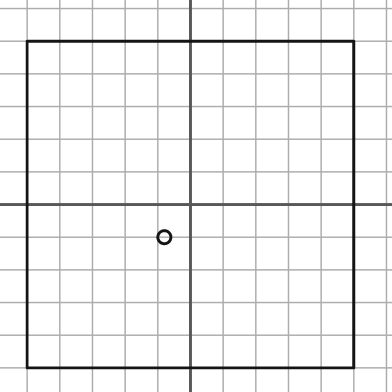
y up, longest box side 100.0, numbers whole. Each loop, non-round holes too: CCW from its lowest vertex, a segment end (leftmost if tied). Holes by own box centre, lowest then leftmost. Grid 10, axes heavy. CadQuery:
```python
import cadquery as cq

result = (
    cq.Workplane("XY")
    .moveTo(-50.0, -50.0)
    .lineTo(50.0, -50.0)
    .lineTo(50.0, 50.0)
    .lineTo(-50.0, 50.0)
    .close()
    .moveTo(-8.0, -10.0)
    .circle(2.0)
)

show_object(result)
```